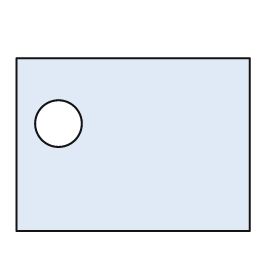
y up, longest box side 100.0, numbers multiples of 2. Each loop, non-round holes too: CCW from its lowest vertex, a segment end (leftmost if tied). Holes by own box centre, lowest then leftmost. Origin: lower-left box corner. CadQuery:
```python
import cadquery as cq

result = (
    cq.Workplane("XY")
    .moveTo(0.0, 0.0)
    .lineTo(100.0, 0.0)
    .lineTo(100.0, 74.0)
    .lineTo(0.0, 74.0)
    .close()
    .moveTo(18.0, 46.0)
    .circle(10.0)
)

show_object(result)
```